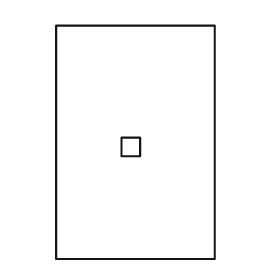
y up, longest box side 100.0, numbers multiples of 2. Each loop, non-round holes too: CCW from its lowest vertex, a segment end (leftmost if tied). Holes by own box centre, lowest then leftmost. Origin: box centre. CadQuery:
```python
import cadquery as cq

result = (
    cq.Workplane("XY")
    .moveTo(-34.0, -50.0)
    .lineTo(34.0, -50.0)
    .lineTo(34.0, 50.0)
    .lineTo(-34.0, 50.0)
    .close()
    .moveTo(-6.0, -6.0)
    .lineTo(2.0, -6.0)
    .lineTo(2.0, 2.0)
    .lineTo(-6.0, 2.0)
    .close()
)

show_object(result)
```